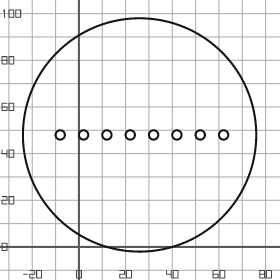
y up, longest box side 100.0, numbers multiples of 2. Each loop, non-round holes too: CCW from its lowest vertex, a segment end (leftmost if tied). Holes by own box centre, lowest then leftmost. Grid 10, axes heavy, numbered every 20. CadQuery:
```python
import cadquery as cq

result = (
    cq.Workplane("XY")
    .moveTo(26.0, 48.0)
    .circle(50.0)
    .moveTo(-8.0, 48.0)
    .circle(2.0)
    .moveTo(2.0, 48.0)
    .circle(2.0)
    .moveTo(12.0, 48.0)
    .circle(2.0)
    .moveTo(22.0, 48.0)
    .circle(2.0)
    .moveTo(32.0, 48.0)
    .circle(2.0)
    .moveTo(42.0, 48.0)
    .circle(2.0)
    .moveTo(52.0, 48.0)
    .circle(2.0)
    .moveTo(62.0, 48.0)
    .circle(2.0)
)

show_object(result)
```